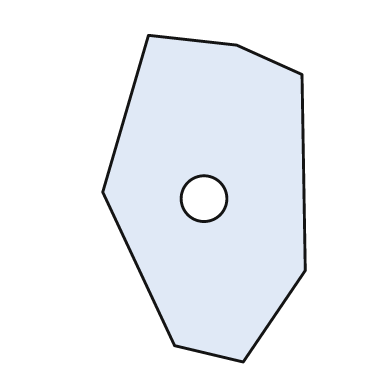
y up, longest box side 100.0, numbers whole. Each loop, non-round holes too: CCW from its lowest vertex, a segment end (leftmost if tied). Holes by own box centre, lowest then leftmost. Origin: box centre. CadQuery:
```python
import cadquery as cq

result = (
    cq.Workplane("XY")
    .moveTo(12.0, -50.0)
    .lineTo(31.0, -22.0)
    .lineTo(30.0, 38.0)
    .lineTo(10.0, 47.0)
    .lineTo(-17.0, 50.0)
    .lineTo(-31.0, 2.0)
    .lineTo(-9.0, -45.0)
    .close()
    .moveTo(0.0, 0.0)
    .circle(7.0)
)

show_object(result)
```